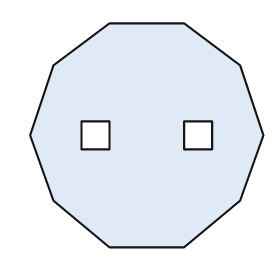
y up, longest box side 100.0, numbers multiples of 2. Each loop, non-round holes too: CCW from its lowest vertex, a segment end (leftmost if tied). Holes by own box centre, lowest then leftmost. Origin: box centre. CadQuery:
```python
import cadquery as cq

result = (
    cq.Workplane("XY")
    .moveTo(-16.0, -48.0)
    .lineTo(16.0, -48.0)
    .lineTo(40.0, -28.0)
    .lineTo(50.0, 0.0)
    .lineTo(40.0, 30.0)
    .lineTo(16.0, 48.0)
    .lineTo(-16.0, 48.0)
    .lineTo(-40.0, 30.0)
    .lineTo(-50.0, 0.0)
    .lineTo(-40.0, -28.0)
    .close()
    .moveTo(-28.0, -6.0)
    .lineTo(-16.0, -6.0)
    .lineTo(-16.0, 6.0)
    .lineTo(-28.0, 6.0)
    .close()
    .moveTo(16.0, -6.0)
    .lineTo(28.0, -6.0)
    .lineTo(28.0, 6.0)
    .lineTo(16.0, 6.0)
    .close()
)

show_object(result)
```